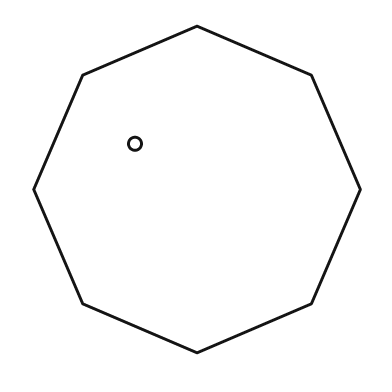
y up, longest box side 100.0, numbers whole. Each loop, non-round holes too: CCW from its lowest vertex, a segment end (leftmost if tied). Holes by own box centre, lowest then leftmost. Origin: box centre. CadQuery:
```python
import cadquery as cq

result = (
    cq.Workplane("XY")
    .moveTo(0.0, -50.0)
    .lineTo(35.0, -35.0)
    .lineTo(50.0, 0.0)
    .lineTo(35.0, 35.0)
    .lineTo(0.0, 50.0)
    .lineTo(-35.0, 35.0)
    .lineTo(-50.0, 0.0)
    .lineTo(-35.0, -35.0)
    .close()
    .moveTo(-19.0, 14.0)
    .circle(2.0)
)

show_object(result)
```